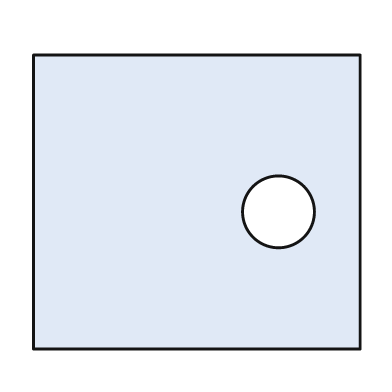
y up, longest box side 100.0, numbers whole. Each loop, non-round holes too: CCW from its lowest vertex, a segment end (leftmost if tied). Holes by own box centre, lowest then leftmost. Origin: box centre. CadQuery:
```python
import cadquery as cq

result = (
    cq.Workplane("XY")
    .moveTo(-50.0, -45.0)
    .lineTo(50.0, -45.0)
    .lineTo(50.0, 45.0)
    .lineTo(-50.0, 45.0)
    .close()
    .moveTo(25.0, -3.0)
    .circle(11.0)
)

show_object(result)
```